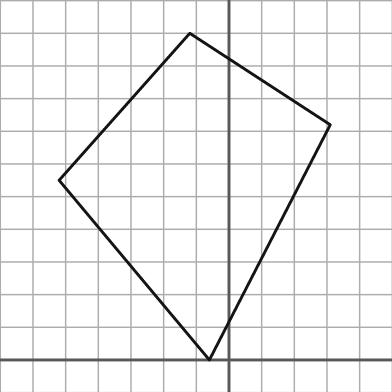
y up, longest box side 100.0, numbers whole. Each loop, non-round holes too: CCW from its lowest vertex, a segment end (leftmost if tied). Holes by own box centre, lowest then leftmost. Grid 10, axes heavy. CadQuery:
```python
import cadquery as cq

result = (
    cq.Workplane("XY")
    .moveTo(-6.0, 0.0)
    .lineTo(31.0, 72.0)
    .lineTo(-12.0, 100.0)
    .lineTo(-52.0, 55.0)
    .close()
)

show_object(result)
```